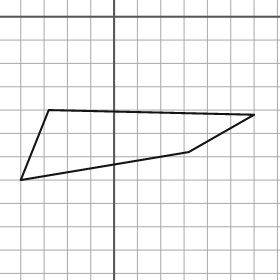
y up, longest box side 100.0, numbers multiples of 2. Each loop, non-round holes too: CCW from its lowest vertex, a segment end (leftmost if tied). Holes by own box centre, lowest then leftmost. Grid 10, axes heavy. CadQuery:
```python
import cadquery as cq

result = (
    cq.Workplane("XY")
    .moveTo(-40.0, -70.0)
    .lineTo(32.0, -58.0)
    .lineTo(60.0, -42.0)
    .lineTo(-28.0, -40.0)
    .close()
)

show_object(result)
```